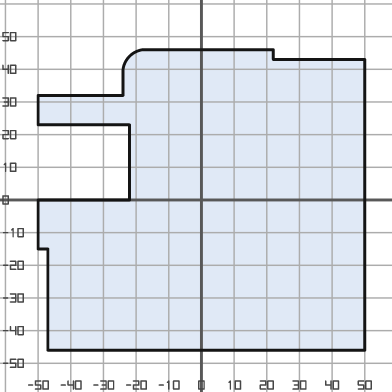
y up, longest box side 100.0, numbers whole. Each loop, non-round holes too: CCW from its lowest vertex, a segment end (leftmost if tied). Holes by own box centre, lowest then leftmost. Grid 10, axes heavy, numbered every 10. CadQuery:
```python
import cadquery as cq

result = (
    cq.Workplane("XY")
    .moveTo(-47.0, -46.0)
    .lineTo(50.0, -46.0)
    .lineTo(50.0, 43.0)
    .lineTo(22.0, 43.0)
    .lineTo(22.0, 46.0)
    .lineTo(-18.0, 46.0)
    .threePointArc((-22.0, 44.0), (-24.0, 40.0))
    .lineTo(-24.0, 32.0)
    .lineTo(-50.0, 32.0)
    .lineTo(-50.0, 23.0)
    .lineTo(-22.0, 23.0)
    .lineTo(-22.0, 0.0)
    .lineTo(-50.0, 0.0)
    .lineTo(-50.0, -15.0)
    .lineTo(-47.0, -15.0)
    .close()
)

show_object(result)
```